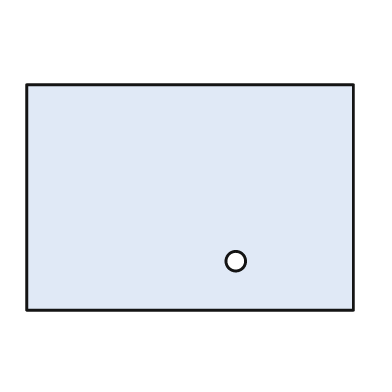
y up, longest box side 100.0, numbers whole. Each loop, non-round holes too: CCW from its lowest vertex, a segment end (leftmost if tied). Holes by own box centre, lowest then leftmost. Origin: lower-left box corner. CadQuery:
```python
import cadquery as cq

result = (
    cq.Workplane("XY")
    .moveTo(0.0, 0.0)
    .lineTo(100.0, 0.0)
    .lineTo(100.0, 69.0)
    .lineTo(0.0, 69.0)
    .close()
    .moveTo(64.0, 15.0)
    .circle(3.0)
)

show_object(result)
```